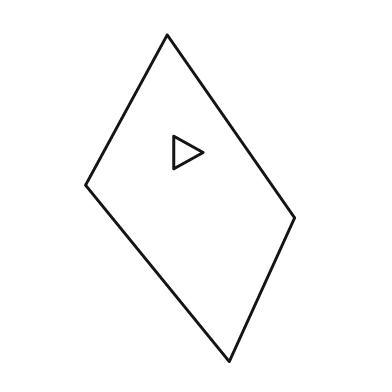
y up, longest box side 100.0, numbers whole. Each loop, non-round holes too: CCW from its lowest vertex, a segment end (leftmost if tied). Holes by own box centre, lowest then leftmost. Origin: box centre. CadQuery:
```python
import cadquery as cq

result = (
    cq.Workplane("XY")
    .moveTo(12.0, -50.0)
    .lineTo(32.0, -6.0)
    .lineTo(-7.0, 50.0)
    .lineTo(-32.0, 4.0)
    .close()
    .moveTo(-5.0, 9.0)
    .lineTo(4.0, 14.0)
    .lineTo(-5.0, 19.0)
    .close()
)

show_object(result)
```